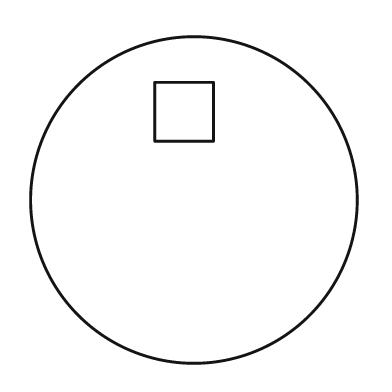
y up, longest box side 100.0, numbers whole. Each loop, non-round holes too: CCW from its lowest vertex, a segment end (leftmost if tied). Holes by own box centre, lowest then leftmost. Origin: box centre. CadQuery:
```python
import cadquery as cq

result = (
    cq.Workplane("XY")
    .moveTo(0.0, 0.0)
    .circle(50.0)
    .moveTo(-12.0, 18.0)
    .lineTo(6.0, 18.0)
    .lineTo(6.0, 36.0)
    .lineTo(-12.0, 36.0)
    .close()
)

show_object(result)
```